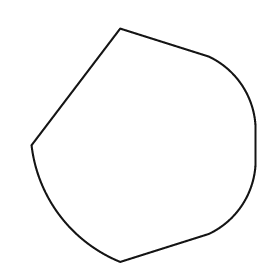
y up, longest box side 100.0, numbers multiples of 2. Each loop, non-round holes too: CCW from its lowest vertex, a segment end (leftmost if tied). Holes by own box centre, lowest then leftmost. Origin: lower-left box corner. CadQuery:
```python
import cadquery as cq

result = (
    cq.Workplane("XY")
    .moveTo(38.0, 0.0)
    .lineTo(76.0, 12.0)
    .threePointArc((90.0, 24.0), (96.0, 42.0))
    .lineTo(96.0, 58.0)
    .threePointArc((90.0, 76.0), (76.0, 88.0))
    .lineTo(38.0, 100.0)
    .lineTo(0.0, 50.0)
    .threePointArc((12.0, 20.0), (38.0, 0.0))
    .close()
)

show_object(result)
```